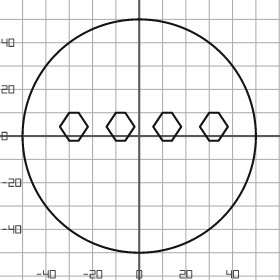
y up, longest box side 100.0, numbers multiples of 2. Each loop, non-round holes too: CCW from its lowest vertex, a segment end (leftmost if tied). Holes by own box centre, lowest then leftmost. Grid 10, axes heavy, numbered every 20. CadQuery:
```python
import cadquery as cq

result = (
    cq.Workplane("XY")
    .moveTo(0.0, 0.0)
    .circle(50.0)
    .moveTo(-30.0, -2.0)
    .lineTo(-26.0, -2.0)
    .lineTo(-22.0, 4.0)
    .lineTo(-26.0, 10.0)
    .lineTo(-30.0, 10.0)
    .lineTo(-34.0, 4.0)
    .close()
    .moveTo(-10.0, -2.0)
    .lineTo(-6.0, -2.0)
    .lineTo(-2.0, 4.0)
    .lineTo(-6.0, 10.0)
    .lineTo(-10.0, 10.0)
    .lineTo(-14.0, 4.0)
    .close()
    .moveTo(10.0, -2.0)
    .lineTo(14.0, -2.0)
    .lineTo(18.0, 4.0)
    .lineTo(14.0, 10.0)
    .lineTo(10.0, 10.0)
    .lineTo(6.0, 4.0)
    .close()
    .moveTo(30.0, -2.0)
    .lineTo(34.0, -2.0)
    .lineTo(38.0, 4.0)
    .lineTo(34.0, 10.0)
    .lineTo(30.0, 10.0)
    .lineTo(26.0, 4.0)
    .close()
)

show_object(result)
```